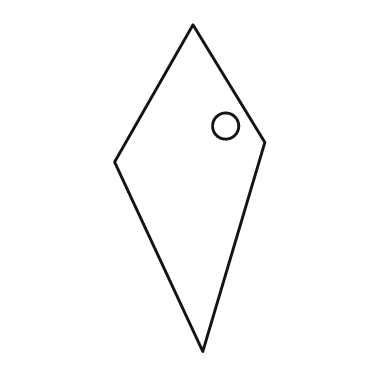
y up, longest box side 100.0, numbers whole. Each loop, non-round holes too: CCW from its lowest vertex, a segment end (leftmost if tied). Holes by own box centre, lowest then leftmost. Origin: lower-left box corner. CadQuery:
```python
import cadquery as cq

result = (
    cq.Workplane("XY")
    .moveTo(27.0, 0.0)
    .lineTo(46.0, 64.0)
    .lineTo(24.0, 100.0)
    .lineTo(0.0, 58.0)
    .close()
    .moveTo(34.0, 69.0)
    .circle(4.0)
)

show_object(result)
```